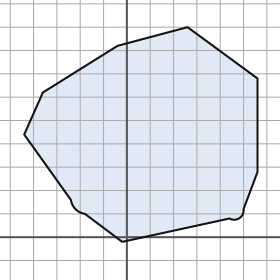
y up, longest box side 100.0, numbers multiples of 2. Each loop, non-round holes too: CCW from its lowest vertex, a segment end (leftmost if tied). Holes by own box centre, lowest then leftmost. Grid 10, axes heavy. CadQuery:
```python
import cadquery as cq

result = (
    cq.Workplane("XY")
    .moveTo(-2.0, -2.0)
    .lineTo(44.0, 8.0)
    .threePointArc((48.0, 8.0), (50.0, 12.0))
    .lineTo(56.0, 28.0)
    .lineTo(56.0, 68.0)
    .lineTo(26.0, 90.0)
    .lineTo(-4.0, 82.0)
    .lineTo(-36.0, 62.0)
    .lineTo(-44.0, 44.0)
    .lineTo(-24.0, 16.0)
    .threePointArc((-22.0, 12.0), (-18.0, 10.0))
    .close()
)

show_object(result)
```